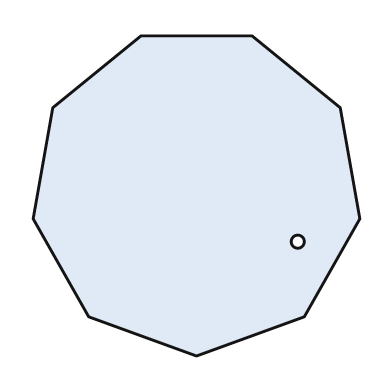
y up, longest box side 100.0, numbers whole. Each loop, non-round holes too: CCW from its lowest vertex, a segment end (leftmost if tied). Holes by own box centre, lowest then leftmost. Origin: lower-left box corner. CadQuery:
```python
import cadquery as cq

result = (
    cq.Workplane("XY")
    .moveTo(50.0, 0.0)
    .lineTo(83.0, 12.0)
    .lineTo(100.0, 42.0)
    .lineTo(94.0, 76.0)
    .lineTo(67.0, 98.0)
    .lineTo(33.0, 98.0)
    .lineTo(6.0, 76.0)
    .lineTo(0.0, 42.0)
    .lineTo(17.0, 12.0)
    .close()
    .moveTo(81.0, 35.0)
    .circle(2.0)
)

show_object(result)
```